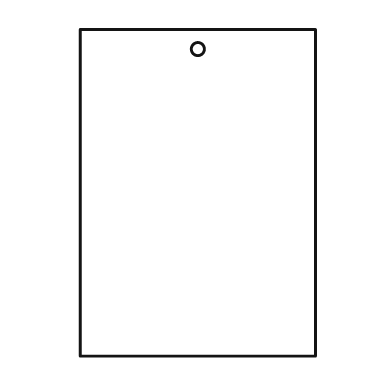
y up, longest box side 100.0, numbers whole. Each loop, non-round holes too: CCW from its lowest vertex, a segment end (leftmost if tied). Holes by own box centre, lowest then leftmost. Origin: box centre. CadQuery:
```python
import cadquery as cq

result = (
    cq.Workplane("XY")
    .moveTo(-36.0, -50.0)
    .lineTo(36.0, -50.0)
    .lineTo(36.0, 50.0)
    .lineTo(-36.0, 50.0)
    .close()
    .moveTo(0.0, 44.0)
    .circle(2.0)
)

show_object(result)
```